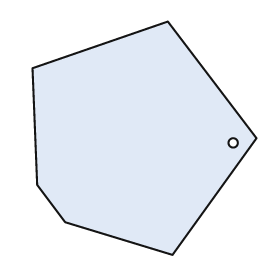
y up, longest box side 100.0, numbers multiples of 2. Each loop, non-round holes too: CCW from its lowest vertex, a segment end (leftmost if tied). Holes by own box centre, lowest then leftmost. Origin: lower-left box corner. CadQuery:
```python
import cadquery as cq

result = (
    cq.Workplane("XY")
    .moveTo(60.0, 0.0)
    .lineTo(96.0, 50.0)
    .lineTo(58.0, 100.0)
    .lineTo(0.0, 80.0)
    .lineTo(2.0, 30.0)
    .lineTo(14.0, 14.0)
    .close()
    .moveTo(86.0, 48.0)
    .circle(2.0)
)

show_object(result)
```